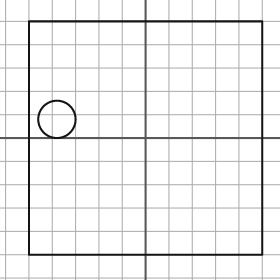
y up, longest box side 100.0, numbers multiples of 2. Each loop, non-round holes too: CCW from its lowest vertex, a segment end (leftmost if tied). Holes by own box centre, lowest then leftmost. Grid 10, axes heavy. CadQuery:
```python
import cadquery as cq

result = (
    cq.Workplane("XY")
    .moveTo(-50.0, -50.0)
    .lineTo(50.0, -50.0)
    .lineTo(50.0, 50.0)
    .lineTo(-50.0, 50.0)
    .close()
    .moveTo(-38.0, 8.0)
    .circle(8.0)
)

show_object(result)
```